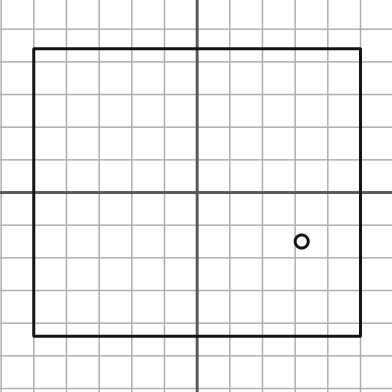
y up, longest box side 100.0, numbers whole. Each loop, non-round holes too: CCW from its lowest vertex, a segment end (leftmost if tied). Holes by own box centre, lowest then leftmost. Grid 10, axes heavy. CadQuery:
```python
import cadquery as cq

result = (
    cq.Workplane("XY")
    .moveTo(-50.0, -44.0)
    .lineTo(50.0, -44.0)
    .lineTo(50.0, 44.0)
    .lineTo(-50.0, 44.0)
    .close()
    .moveTo(32.0, -15.0)
    .circle(2.0)
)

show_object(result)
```